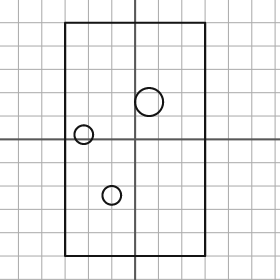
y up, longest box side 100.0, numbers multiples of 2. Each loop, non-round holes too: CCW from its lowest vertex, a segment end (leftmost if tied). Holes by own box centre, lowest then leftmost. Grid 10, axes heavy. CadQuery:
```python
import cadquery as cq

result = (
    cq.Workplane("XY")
    .moveTo(-30.0, -50.0)
    .lineTo(30.0, -50.0)
    .lineTo(30.0, 50.0)
    .lineTo(-30.0, 50.0)
    .close()
    .moveTo(-10.0, -24.0)
    .circle(4.0)
    .moveTo(-22.0, 2.0)
    .circle(4.0)
    .moveTo(6.0, 16.0)
    .circle(6.0)
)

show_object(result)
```